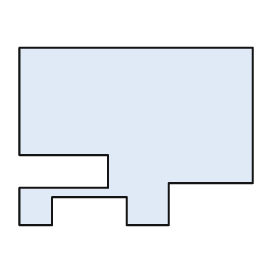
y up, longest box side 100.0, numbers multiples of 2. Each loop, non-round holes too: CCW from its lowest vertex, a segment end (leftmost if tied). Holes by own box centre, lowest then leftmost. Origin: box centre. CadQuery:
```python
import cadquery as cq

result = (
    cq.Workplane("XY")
    .moveTo(-50.0, -38.0)
    .lineTo(-36.0, -38.0)
    .lineTo(-36.0, -26.0)
    .lineTo(-4.0, -26.0)
    .lineTo(-4.0, -38.0)
    .lineTo(14.0, -38.0)
    .lineTo(14.0, -20.0)
    .lineTo(50.0, -20.0)
    .lineTo(50.0, 38.0)
    .lineTo(-50.0, 38.0)
    .lineTo(-50.0, -8.0)
    .lineTo(-12.0, -8.0)
    .lineTo(-12.0, -22.0)
    .lineTo(-50.0, -22.0)
    .close()
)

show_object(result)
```